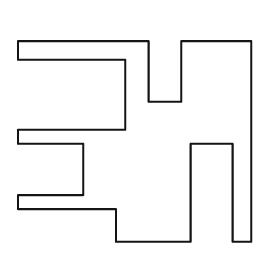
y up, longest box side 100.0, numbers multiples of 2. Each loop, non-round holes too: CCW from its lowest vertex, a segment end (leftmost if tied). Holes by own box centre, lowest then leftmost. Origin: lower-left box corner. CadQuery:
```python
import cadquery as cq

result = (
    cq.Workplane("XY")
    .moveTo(42.0, 0.0)
    .lineTo(74.0, 0.0)
    .lineTo(74.0, 42.0)
    .lineTo(92.0, 42.0)
    .lineTo(92.0, 0.0)
    .lineTo(100.0, 0.0)
    .lineTo(100.0, 86.0)
    .lineTo(70.0, 86.0)
    .lineTo(70.0, 60.0)
    .lineTo(56.0, 60.0)
    .lineTo(56.0, 86.0)
    .lineTo(0.0, 86.0)
    .lineTo(0.0, 78.0)
    .lineTo(46.0, 78.0)
    .lineTo(46.0, 48.0)
    .lineTo(0.0, 48.0)
    .lineTo(0.0, 42.0)
    .lineTo(28.0, 42.0)
    .lineTo(28.0, 20.0)
    .lineTo(0.0, 20.0)
    .lineTo(0.0, 14.0)
    .lineTo(42.0, 14.0)
    .close()
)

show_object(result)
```